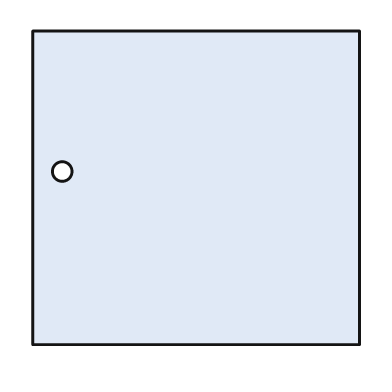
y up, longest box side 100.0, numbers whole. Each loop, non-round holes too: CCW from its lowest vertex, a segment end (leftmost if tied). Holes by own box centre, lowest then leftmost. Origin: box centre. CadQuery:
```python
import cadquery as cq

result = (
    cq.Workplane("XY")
    .moveTo(-50.0, -48.0)
    .lineTo(50.0, -48.0)
    .lineTo(50.0, 48.0)
    .lineTo(-50.0, 48.0)
    .close()
    .moveTo(-41.0, 5.0)
    .circle(3.0)
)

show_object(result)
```